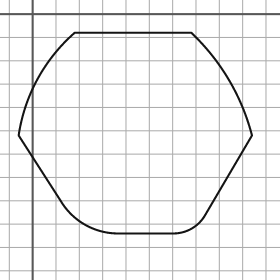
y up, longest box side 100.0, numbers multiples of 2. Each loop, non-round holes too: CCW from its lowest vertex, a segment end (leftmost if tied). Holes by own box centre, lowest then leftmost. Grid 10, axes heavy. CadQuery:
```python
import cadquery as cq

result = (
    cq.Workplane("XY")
    .moveTo(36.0, -94.0)
    .lineTo(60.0, -94.0)
    .threePointArc((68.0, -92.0), (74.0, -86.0))
    .lineTo(94.0, -52.0)
    .threePointArc((84.0, -28.0), (68.0, -8.0))
    .lineTo(18.0, -8.0)
    .threePointArc((2.0, -28.0), (-6.0, -52.0))
    .lineTo(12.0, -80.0)
    .threePointArc((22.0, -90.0), (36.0, -94.0))
    .close()
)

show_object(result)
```